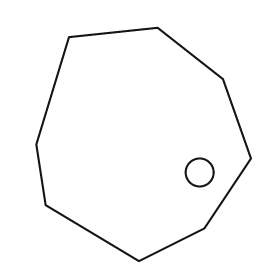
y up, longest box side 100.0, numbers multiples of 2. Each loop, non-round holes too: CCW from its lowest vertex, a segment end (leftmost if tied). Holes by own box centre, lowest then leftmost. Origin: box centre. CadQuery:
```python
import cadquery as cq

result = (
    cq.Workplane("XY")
    .moveTo(-2.0, -50.0)
    .lineTo(26.0, -36.0)
    .lineTo(46.0, -6.0)
    .lineTo(34.0, 28.0)
    .lineTo(6.0, 50.0)
    .lineTo(-32.0, 46.0)
    .lineTo(-46.0, 0.0)
    .lineTo(-42.0, -26.0)
    .close()
    .moveTo(24.0, -12.0)
    .circle(6.0)
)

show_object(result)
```